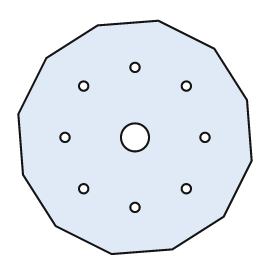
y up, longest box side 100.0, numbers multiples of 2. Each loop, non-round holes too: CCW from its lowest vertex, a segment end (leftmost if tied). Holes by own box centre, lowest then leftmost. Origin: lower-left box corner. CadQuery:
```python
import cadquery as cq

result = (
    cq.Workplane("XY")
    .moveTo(40.0, 0.0)
    .lineTo(66.0, 2.0)
    .lineTo(88.0, 16.0)
    .lineTo(100.0, 40.0)
    .lineTo(98.0, 66.0)
    .lineTo(84.0, 88.0)
    .lineTo(60.0, 100.0)
    .lineTo(34.0, 98.0)
    .lineTo(12.0, 84.0)
    .lineTo(0.0, 60.0)
    .lineTo(2.0, 34.0)
    .lineTo(16.0, 12.0)
    .close()
    .moveTo(50.0, 20.0)
    .circle(2.0)
    .moveTo(28.0, 28.0)
    .circle(2.0)
    .moveTo(72.0, 28.0)
    .circle(2.0)
    .moveTo(20.0, 50.0)
    .circle(2.0)
    .moveTo(50.0, 50.0)
    .circle(6.0)
    .moveTo(80.0, 50.0)
    .circle(2.0)
    .moveTo(28.0, 72.0)
    .circle(2.0)
    .moveTo(72.0, 72.0)
    .circle(2.0)
    .moveTo(50.0, 80.0)
    .circle(2.0)
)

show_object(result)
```